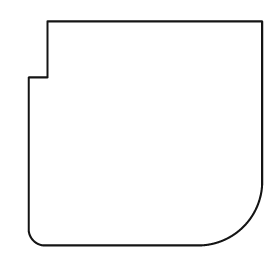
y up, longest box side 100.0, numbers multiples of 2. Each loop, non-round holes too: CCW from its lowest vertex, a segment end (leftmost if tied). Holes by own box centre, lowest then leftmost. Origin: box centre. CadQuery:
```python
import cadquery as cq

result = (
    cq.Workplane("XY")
    .moveTo(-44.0, -48.0)
    .lineTo(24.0, -48.0)
    .threePointArc((42.0, -40.0), (50.0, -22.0))
    .lineTo(50.0, 48.0)
    .lineTo(-42.0, 48.0)
    .lineTo(-42.0, 24.0)
    .lineTo(-50.0, 24.0)
    .lineTo(-50.0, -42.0)
    .threePointArc((-48.0, -46.0), (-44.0, -48.0))
    .close()
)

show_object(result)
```